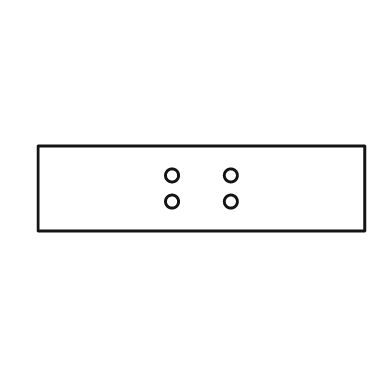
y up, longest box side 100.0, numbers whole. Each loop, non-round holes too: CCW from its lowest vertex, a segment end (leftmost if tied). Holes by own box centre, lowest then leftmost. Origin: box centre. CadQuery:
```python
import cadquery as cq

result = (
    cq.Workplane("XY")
    .moveTo(-50.0, -13.0)
    .lineTo(50.0, -13.0)
    .lineTo(50.0, 13.0)
    .lineTo(-50.0, 13.0)
    .close()
    .moveTo(-9.0, -4.0)
    .circle(2.0)
    .moveTo(9.0, -4.0)
    .circle(2.0)
    .moveTo(-9.0, 4.0)
    .circle(2.0)
    .moveTo(9.0, 4.0)
    .circle(2.0)
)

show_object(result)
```